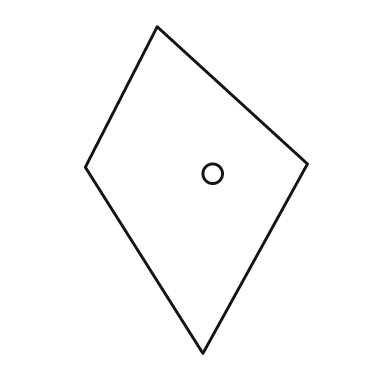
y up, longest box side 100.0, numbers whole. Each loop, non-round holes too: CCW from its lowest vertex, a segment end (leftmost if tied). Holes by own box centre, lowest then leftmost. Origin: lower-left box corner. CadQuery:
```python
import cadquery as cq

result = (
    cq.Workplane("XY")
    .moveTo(36.0, 0.0)
    .lineTo(68.0, 58.0)
    .lineTo(22.0, 100.0)
    .lineTo(0.0, 57.0)
    .close()
    .moveTo(39.0, 55.0)
    .circle(3.0)
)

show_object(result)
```